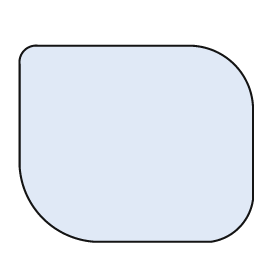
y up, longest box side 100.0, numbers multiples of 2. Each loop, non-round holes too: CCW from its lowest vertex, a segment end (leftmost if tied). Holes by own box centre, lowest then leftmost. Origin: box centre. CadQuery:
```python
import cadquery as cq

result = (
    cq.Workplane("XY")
    .moveTo(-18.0, -42.0)
    .lineTo(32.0, -42.0)
    .threePointArc((44.0, -36.0), (50.0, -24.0))
    .lineTo(50.0, 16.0)
    .threePointArc((42.0, 34.0), (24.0, 42.0))
    .lineTo(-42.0, 42.0)
    .threePointArc((-48.0, 40.0), (-50.0, 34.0))
    .lineTo(-50.0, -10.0)
    .threePointArc((-40.0, -32.0), (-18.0, -42.0))
    .close()
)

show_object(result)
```